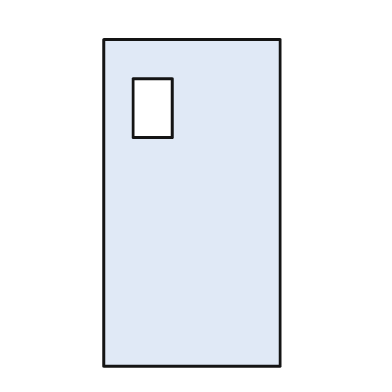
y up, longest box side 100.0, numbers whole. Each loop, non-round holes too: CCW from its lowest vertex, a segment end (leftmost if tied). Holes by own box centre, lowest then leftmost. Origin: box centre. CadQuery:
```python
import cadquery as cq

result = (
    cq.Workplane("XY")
    .moveTo(-27.0, -50.0)
    .lineTo(27.0, -50.0)
    .lineTo(27.0, 50.0)
    .lineTo(-27.0, 50.0)
    .close()
    .moveTo(-18.0, 20.0)
    .lineTo(-6.0, 20.0)
    .lineTo(-6.0, 38.0)
    .lineTo(-18.0, 38.0)
    .close()
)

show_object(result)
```